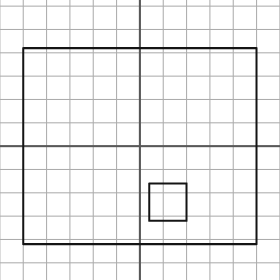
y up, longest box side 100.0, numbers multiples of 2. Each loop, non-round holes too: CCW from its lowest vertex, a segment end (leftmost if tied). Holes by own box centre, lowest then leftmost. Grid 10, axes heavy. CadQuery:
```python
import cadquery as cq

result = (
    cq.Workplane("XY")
    .moveTo(-50.0, -42.0)
    .lineTo(50.0, -42.0)
    .lineTo(50.0, 42.0)
    .lineTo(-50.0, 42.0)
    .close()
    .moveTo(4.0, -32.0)
    .lineTo(20.0, -32.0)
    .lineTo(20.0, -16.0)
    .lineTo(4.0, -16.0)
    .close()
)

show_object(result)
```